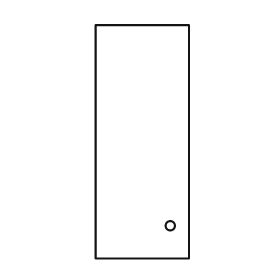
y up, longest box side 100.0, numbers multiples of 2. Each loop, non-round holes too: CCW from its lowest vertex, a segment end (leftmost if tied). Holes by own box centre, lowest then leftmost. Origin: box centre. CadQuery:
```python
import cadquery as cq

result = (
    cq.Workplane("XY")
    .moveTo(-20.0, -50.0)
    .lineTo(20.0, -50.0)
    .lineTo(20.0, 50.0)
    .lineTo(-20.0, 50.0)
    .close()
    .moveTo(12.0, -36.0)
    .circle(2.0)
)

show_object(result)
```